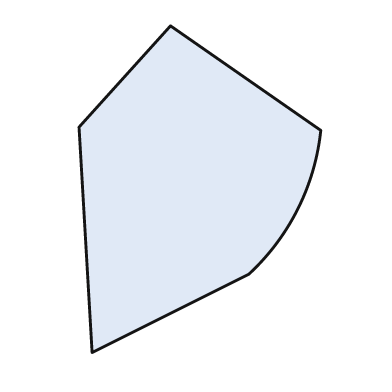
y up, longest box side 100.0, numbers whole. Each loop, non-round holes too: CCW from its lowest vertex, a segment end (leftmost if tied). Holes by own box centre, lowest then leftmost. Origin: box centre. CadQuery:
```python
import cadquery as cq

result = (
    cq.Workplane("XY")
    .moveTo(-33.0, -50.0)
    .lineTo(15.0, -26.0)
    .threePointArc((30.0, -6.0), (37.0, 18.0))
    .lineTo(-9.0, 50.0)
    .lineTo(-37.0, 19.0)
    .close()
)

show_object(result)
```